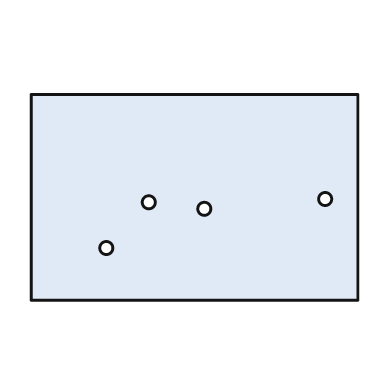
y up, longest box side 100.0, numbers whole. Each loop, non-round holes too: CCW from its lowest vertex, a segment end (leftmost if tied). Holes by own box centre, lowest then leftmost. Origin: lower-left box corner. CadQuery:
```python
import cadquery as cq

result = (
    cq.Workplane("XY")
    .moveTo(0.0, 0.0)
    .lineTo(100.0, 0.0)
    .lineTo(100.0, 63.0)
    .lineTo(0.0, 63.0)
    .close()
    .moveTo(23.0, 16.0)
    .circle(2.0)
    .moveTo(53.0, 28.0)
    .circle(2.0)
    .moveTo(36.0, 30.0)
    .circle(2.0)
    .moveTo(90.0, 31.0)
    .circle(2.0)
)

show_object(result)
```